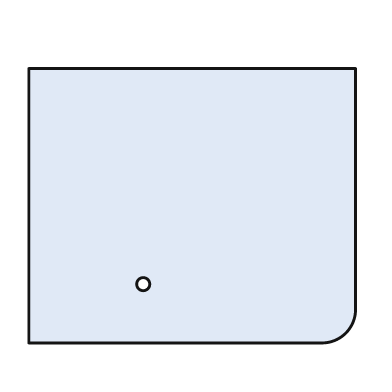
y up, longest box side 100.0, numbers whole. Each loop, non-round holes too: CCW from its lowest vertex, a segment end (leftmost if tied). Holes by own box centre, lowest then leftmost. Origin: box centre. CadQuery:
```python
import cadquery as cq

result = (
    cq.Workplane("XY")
    .moveTo(-50.0, -42.0)
    .lineTo(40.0, -42.0)
    .threePointArc((47.0, -39.0), (50.0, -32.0))
    .lineTo(50.0, 42.0)
    .lineTo(-50.0, 42.0)
    .close()
    .moveTo(-15.0, -24.0)
    .circle(2.0)
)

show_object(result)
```